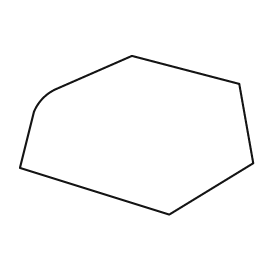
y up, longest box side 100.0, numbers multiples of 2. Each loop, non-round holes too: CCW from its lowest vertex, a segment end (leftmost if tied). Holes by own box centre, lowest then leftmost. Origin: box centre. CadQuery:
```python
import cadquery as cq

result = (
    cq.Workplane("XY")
    .moveTo(14.0, -34.0)
    .lineTo(50.0, -12.0)
    .lineTo(44.0, 22.0)
    .lineTo(-2.0, 34.0)
    .lineTo(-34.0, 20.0)
    .threePointArc((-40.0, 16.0), (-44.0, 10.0))
    .lineTo(-50.0, -14.0)
    .close()
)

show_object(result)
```